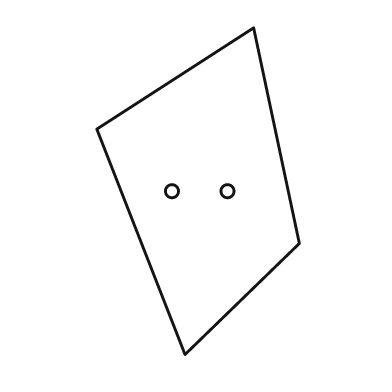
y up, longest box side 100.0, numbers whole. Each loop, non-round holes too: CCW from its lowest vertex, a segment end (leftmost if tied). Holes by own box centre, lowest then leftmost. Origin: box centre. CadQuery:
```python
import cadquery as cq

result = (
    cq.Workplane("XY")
    .moveTo(-4.0, -50.0)
    .lineTo(31.0, -16.0)
    .lineTo(17.0, 50.0)
    .lineTo(-31.0, 19.0)
    .close()
    .moveTo(-8.0, 0.0)
    .circle(2.0)
    .moveTo(9.0, 0.0)
    .circle(2.0)
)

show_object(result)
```